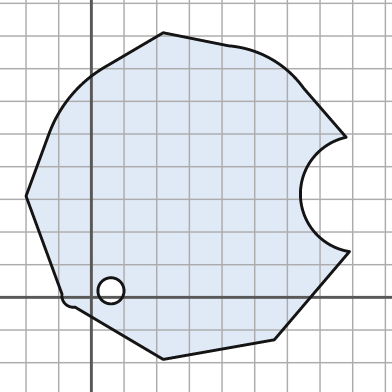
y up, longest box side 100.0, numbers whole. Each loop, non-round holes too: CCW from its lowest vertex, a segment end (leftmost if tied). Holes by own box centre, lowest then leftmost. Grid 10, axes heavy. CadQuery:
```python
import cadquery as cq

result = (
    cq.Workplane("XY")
    .moveTo(22.0, -19.0)
    .lineTo(56.0, -13.0)
    .lineTo(79.0, 14.0)
    .threePointArc((64.0, 31.0), (78.0, 49.0))
    .lineTo(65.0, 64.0)
    .threePointArc((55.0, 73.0), (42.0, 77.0))
    .lineTo(22.0, 81.0)
    .lineTo(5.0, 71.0)
    .threePointArc((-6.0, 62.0), (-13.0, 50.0))
    .lineTo(-20.0, 31.0)
    .lineTo(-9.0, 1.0)
    .threePointArc((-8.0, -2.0), (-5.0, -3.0))
    .close()
    .moveTo(6.0, 2.0)
    .circle(4.0)
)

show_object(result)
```